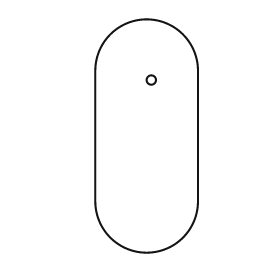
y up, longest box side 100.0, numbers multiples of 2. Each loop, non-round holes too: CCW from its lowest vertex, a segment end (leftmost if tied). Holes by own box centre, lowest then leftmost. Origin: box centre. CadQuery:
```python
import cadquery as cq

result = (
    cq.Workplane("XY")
    .moveTo(-22.0, -28.0)
    .threePointArc((0.0, -50.0), (22.0, -28.0))
    .lineTo(22.0, 28.0)
    .threePointArc((0.0, 50.0), (-22.0, 28.0))
    .close()
    .moveTo(2.0, 24.0)
    .circle(2.0)
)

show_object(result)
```